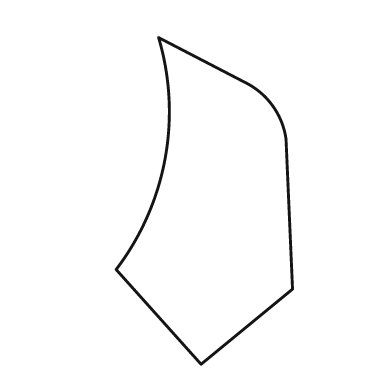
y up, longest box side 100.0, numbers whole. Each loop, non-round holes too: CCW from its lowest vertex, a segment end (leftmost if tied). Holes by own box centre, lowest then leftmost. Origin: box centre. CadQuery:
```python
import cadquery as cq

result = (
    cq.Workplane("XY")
    .moveTo(-1.0, -50.0)
    .lineTo(27.0, -27.0)
    .lineTo(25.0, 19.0)
    .threePointArc((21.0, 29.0), (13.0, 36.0))
    .lineTo(-14.0, 50.0)
    .threePointArc((-12.0, 13.0), (-27.0, -21.0))
    .close()
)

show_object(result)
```